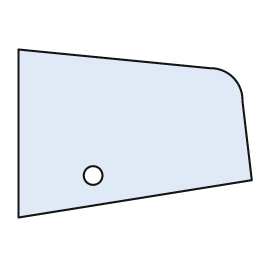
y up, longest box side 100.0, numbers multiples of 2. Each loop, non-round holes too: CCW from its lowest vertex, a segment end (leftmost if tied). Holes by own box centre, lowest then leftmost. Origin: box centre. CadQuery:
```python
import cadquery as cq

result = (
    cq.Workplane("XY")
    .moveTo(-50.0, -36.0)
    .lineTo(50.0, -20.0)
    .lineTo(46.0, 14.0)
    .threePointArc((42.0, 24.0), (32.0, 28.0))
    .lineTo(-50.0, 36.0)
    .close()
    .moveTo(-18.0, -18.0)
    .circle(4.0)
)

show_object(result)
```